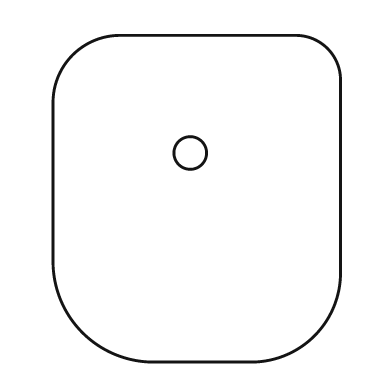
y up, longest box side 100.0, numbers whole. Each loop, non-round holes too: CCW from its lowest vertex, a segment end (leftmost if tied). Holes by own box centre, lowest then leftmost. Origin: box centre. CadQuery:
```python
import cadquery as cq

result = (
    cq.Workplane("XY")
    .moveTo(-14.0, -50.0)
    .lineTo(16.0, -50.0)
    .threePointArc((36.0, -42.0), (44.0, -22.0))
    .lineTo(44.0, 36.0)
    .threePointArc((40.0, 46.0), (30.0, 50.0))
    .lineTo(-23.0, 50.0)
    .threePointArc((-38.0, 44.0), (-44.0, 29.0))
    .lineTo(-44.0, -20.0)
    .threePointArc((-35.0, -41.0), (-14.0, -50.0))
    .close()
    .moveTo(-2.0, 14.0)
    .circle(5.0)
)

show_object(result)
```